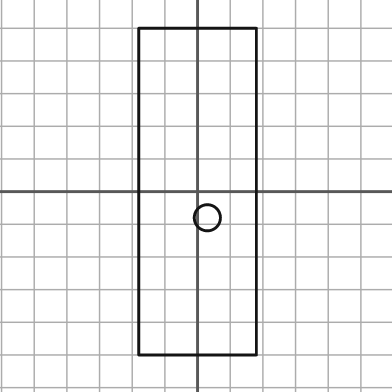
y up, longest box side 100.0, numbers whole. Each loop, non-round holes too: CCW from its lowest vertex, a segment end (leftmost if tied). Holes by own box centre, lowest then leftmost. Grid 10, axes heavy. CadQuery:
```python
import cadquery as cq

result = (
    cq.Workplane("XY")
    .moveTo(-18.0, -50.0)
    .lineTo(18.0, -50.0)
    .lineTo(18.0, 50.0)
    .lineTo(-18.0, 50.0)
    .close()
    .moveTo(3.0, -8.0)
    .circle(4.0)
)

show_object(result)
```